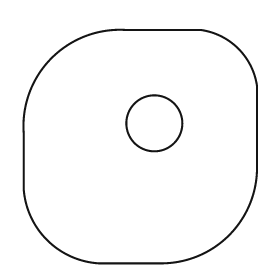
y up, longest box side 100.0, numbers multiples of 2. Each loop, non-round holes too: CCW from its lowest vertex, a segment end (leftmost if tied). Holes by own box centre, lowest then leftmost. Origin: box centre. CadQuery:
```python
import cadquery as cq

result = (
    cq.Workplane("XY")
    .moveTo(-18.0, -50.0)
    .lineTo(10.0, -50.0)
    .threePointArc((38.0, -38.0), (50.0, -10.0))
    .lineTo(50.0, 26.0)
    .threePointArc((42.0, 42.0), (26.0, 50.0))
    .lineTo(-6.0, 50.0)
    .threePointArc((-38.0, 38.0), (-50.0, 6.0))
    .lineTo(-50.0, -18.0)
    .threePointArc((-40.0, -40.0), (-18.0, -50.0))
    .close()
    .moveTo(6.0, 10.0)
    .circle(12.0)
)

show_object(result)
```